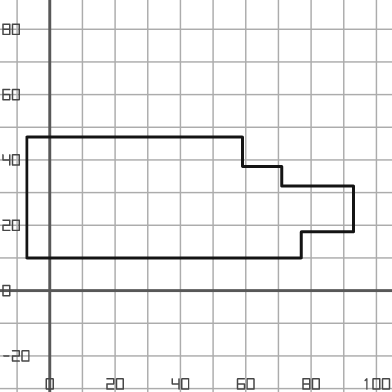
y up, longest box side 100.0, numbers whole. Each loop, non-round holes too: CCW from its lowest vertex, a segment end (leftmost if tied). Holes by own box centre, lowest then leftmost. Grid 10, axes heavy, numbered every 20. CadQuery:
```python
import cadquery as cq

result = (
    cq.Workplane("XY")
    .moveTo(-7.0, 10.0)
    .lineTo(77.0, 10.0)
    .lineTo(77.0, 18.0)
    .lineTo(93.0, 18.0)
    .lineTo(93.0, 32.0)
    .lineTo(71.0, 32.0)
    .lineTo(71.0, 38.0)
    .lineTo(59.0, 38.0)
    .lineTo(59.0, 47.0)
    .lineTo(-7.0, 47.0)
    .close()
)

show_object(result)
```